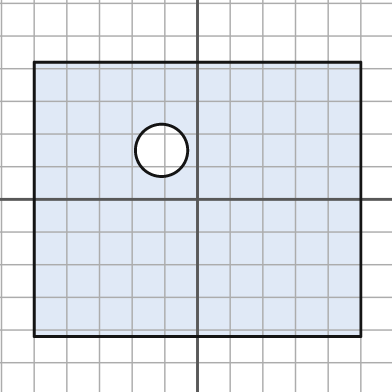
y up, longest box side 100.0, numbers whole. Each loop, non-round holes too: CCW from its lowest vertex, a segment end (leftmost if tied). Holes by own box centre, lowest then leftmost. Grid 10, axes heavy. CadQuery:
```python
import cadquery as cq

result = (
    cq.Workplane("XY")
    .moveTo(-50.0, -42.0)
    .lineTo(50.0, -42.0)
    .lineTo(50.0, 42.0)
    .lineTo(-50.0, 42.0)
    .close()
    .moveTo(-11.0, 15.0)
    .circle(8.0)
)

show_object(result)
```